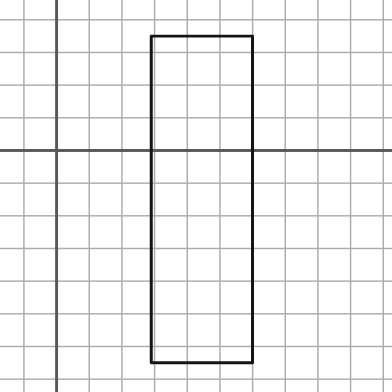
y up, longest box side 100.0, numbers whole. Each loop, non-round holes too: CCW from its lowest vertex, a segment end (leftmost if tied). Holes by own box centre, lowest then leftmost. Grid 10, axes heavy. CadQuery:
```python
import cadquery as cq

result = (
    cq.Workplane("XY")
    .moveTo(29.0, -65.0)
    .lineTo(60.0, -65.0)
    .lineTo(60.0, 35.0)
    .lineTo(29.0, 35.0)
    .close()
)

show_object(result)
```